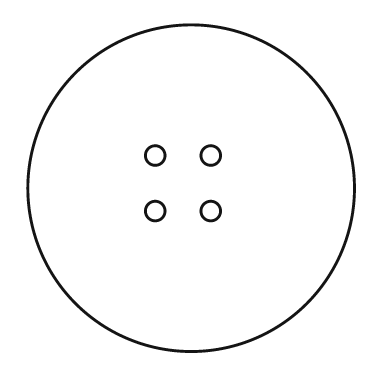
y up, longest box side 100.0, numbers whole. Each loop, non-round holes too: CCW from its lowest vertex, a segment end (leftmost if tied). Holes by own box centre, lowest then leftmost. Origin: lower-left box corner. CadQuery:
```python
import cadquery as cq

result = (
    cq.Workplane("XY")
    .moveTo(50.0, 50.0)
    .circle(50.0)
    .moveTo(39.0, 43.0)
    .circle(3.0)
    .moveTo(56.0, 43.0)
    .circle(3.0)
    .moveTo(39.0, 60.0)
    .circle(3.0)
    .moveTo(56.0, 60.0)
    .circle(3.0)
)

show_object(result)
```